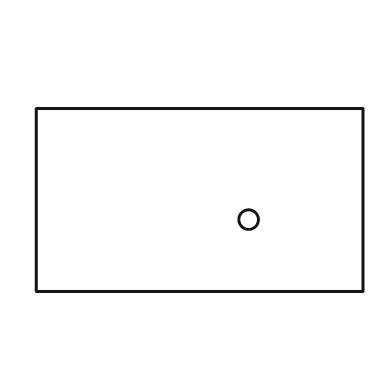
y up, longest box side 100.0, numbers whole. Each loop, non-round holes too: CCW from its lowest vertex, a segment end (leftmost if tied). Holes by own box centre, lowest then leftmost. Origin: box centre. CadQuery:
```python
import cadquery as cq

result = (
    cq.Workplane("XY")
    .moveTo(-50.0, -28.0)
    .lineTo(50.0, -28.0)
    .lineTo(50.0, 28.0)
    .lineTo(-50.0, 28.0)
    .close()
    .moveTo(15.0, -6.0)
    .circle(3.0)
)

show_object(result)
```